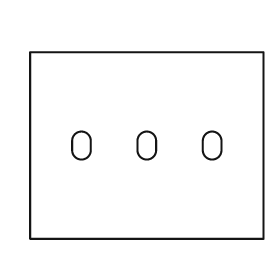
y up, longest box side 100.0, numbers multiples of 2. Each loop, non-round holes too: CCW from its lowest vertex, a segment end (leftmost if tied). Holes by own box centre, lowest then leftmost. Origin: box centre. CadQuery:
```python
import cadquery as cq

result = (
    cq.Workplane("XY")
    .moveTo(-50.0, -40.0)
    .lineTo(50.0, -40.0)
    .lineTo(50.0, 40.0)
    .lineTo(-50.0, 40.0)
    .close()
    .moveTo(-32.0, -2.0)
    .threePointArc((-28.0, -6.0), (-24.0, -2.0))
    .lineTo(-24.0, 2.0)
    .threePointArc((-28.0, 6.0), (-32.0, 2.0))
    .close()
    .moveTo(-4.0, -2.0)
    .threePointArc((0.0, -6.0), (4.0, -2.0))
    .lineTo(4.0, 2.0)
    .threePointArc((0.0, 6.0), (-4.0, 2.0))
    .close()
    .moveTo(24.0, -2.0)
    .threePointArc((28.0, -6.0), (32.0, -2.0))
    .lineTo(32.0, 2.0)
    .threePointArc((28.0, 6.0), (24.0, 2.0))
    .close()
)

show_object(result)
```